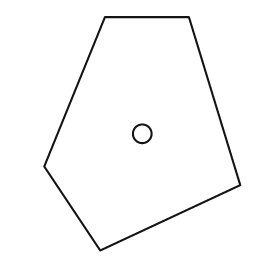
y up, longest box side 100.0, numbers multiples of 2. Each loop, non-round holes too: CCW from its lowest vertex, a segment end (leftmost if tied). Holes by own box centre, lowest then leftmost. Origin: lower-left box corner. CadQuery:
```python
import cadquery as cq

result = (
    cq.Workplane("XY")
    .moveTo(24.0, 0.0)
    .lineTo(84.0, 28.0)
    .lineTo(62.0, 100.0)
    .lineTo(26.0, 100.0)
    .lineTo(0.0, 36.0)
    .close()
    .moveTo(42.0, 50.0)
    .circle(4.0)
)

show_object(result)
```